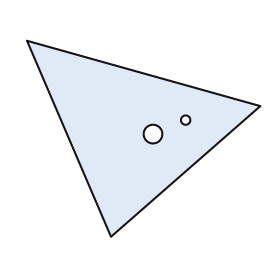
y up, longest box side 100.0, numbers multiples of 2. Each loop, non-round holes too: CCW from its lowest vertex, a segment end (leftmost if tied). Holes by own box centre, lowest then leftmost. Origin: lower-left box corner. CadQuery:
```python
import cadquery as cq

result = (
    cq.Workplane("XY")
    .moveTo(36.0, 0.0)
    .lineTo(100.0, 56.0)
    .lineTo(0.0, 84.0)
    .close()
    .moveTo(54.0, 44.0)
    .circle(4.0)
    .moveTo(68.0, 50.0)
    .circle(2.0)
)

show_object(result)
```